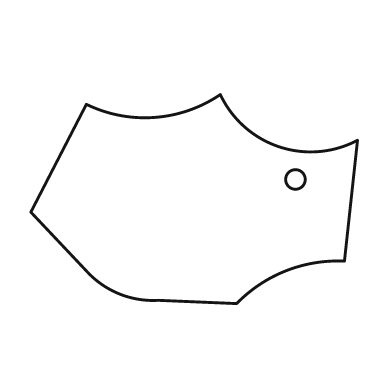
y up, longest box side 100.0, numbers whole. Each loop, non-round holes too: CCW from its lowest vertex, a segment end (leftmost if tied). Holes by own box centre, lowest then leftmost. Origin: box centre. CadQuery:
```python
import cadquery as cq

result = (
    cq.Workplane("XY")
    .moveTo(13.0, -32.0)
    .threePointArc((28.0, -22.0), (46.0, -19.0))
    .lineTo(50.0, 18.0)
    .threePointArc((26.0, 16.0), (8.0, 32.0))
    .threePointArc((-12.0, 25.0), (-33.0, 29.0))
    .lineTo(-50.0, -4.0)
    .lineTo(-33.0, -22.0)
    .threePointArc((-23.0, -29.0), (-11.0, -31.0))
    .close()
    .moveTo(31.0, 6.0)
    .circle(3.0)
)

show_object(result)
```